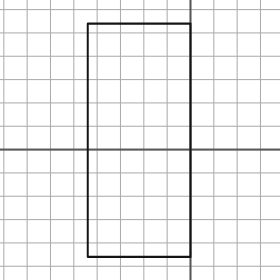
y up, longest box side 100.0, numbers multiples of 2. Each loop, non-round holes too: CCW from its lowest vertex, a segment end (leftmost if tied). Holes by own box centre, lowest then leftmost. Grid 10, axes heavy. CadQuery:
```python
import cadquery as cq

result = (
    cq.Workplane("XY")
    .moveTo(-44.0, -46.0)
    .lineTo(0.0, -46.0)
    .lineTo(0.0, 54.0)
    .lineTo(-44.0, 54.0)
    .close()
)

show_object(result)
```